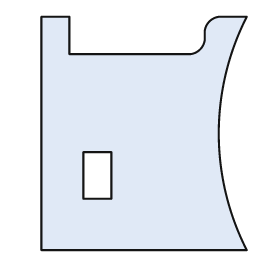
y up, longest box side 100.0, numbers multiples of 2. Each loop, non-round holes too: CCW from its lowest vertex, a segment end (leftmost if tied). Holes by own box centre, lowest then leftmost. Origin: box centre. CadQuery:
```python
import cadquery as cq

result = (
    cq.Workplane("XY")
    .moveTo(-44.0, -50.0)
    .lineTo(44.0, -50.0)
    .threePointArc((32.0, 0.0), (44.0, 50.0))
    .lineTo(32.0, 50.0)
    .threePointArc((28.0, 48.0), (26.0, 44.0))
    .lineTo(26.0, 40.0)
    .threePointArc((24.0, 36.0), (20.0, 34.0))
    .lineTo(-32.0, 34.0)
    .lineTo(-32.0, 50.0)
    .lineTo(-44.0, 50.0)
    .close()
    .moveTo(-26.0, -28.0)
    .lineTo(-14.0, -28.0)
    .lineTo(-14.0, -8.0)
    .lineTo(-26.0, -8.0)
    .close()
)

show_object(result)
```